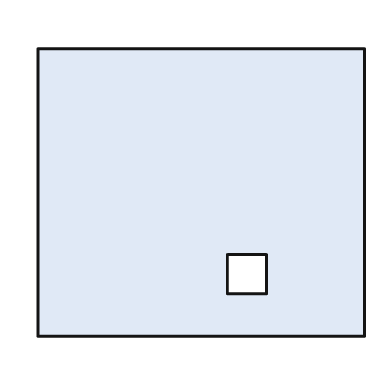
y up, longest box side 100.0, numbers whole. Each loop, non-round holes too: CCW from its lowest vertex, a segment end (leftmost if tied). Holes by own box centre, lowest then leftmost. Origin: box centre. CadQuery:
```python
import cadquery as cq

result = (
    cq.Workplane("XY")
    .moveTo(-50.0, -44.0)
    .lineTo(50.0, -44.0)
    .lineTo(50.0, 44.0)
    .lineTo(-50.0, 44.0)
    .close()
    .moveTo(8.0, -31.0)
    .lineTo(20.0, -31.0)
    .lineTo(20.0, -19.0)
    .lineTo(8.0, -19.0)
    .close()
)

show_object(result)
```